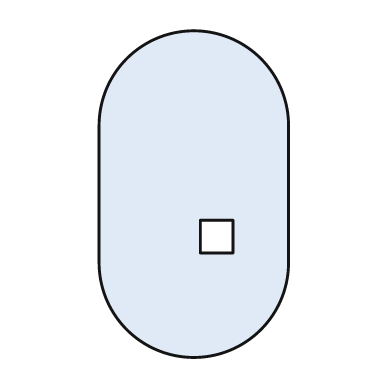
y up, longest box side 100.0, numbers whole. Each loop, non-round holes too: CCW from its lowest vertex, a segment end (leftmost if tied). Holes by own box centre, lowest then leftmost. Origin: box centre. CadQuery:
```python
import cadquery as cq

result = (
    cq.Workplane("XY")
    .moveTo(-29.0, -21.0)
    .threePointArc((0.0, -50.0), (29.0, -21.0))
    .lineTo(29.0, 21.0)
    .threePointArc((0.0, 50.0), (-29.0, 21.0))
    .close()
    .moveTo(2.0, -18.0)
    .lineTo(12.0, -18.0)
    .lineTo(12.0, -8.0)
    .lineTo(2.0, -8.0)
    .close()
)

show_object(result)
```